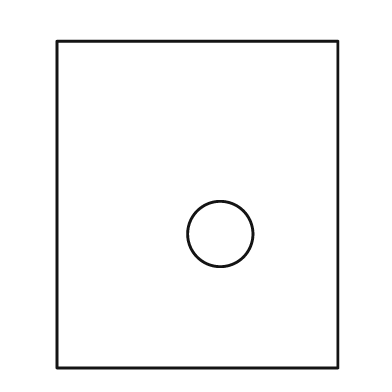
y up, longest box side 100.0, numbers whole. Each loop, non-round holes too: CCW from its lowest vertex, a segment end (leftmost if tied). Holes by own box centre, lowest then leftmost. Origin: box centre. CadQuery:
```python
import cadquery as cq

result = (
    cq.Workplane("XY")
    .moveTo(-43.0, -50.0)
    .lineTo(43.0, -50.0)
    .lineTo(43.0, 50.0)
    .lineTo(-43.0, 50.0)
    .close()
    .moveTo(7.0, -9.0)
    .circle(10.0)
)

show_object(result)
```